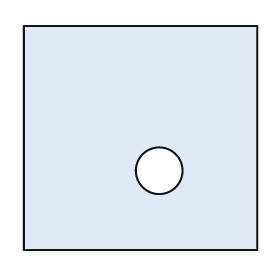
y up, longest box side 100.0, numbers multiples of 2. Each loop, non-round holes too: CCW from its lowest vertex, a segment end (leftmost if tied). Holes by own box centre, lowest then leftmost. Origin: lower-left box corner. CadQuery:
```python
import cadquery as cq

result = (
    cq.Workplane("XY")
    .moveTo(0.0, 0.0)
    .lineTo(100.0, 0.0)
    .lineTo(100.0, 96.0)
    .lineTo(0.0, 96.0)
    .close()
    .moveTo(58.0, 34.0)
    .circle(10.0)
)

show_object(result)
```